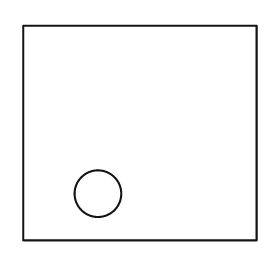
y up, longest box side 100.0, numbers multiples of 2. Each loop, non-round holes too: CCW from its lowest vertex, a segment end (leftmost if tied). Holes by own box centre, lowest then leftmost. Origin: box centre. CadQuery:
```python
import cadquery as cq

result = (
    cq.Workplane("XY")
    .moveTo(-50.0, -46.0)
    .lineTo(50.0, -46.0)
    .lineTo(50.0, 46.0)
    .lineTo(-50.0, 46.0)
    .close()
    .moveTo(-18.0, -26.0)
    .circle(10.0)
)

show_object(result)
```